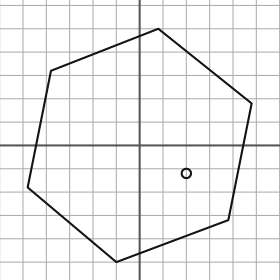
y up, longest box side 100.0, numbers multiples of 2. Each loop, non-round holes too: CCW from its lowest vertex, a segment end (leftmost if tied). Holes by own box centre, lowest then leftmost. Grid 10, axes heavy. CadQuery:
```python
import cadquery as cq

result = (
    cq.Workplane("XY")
    .moveTo(-10.0, -50.0)
    .lineTo(38.0, -32.0)
    .lineTo(48.0, 18.0)
    .lineTo(8.0, 50.0)
    .lineTo(-38.0, 32.0)
    .lineTo(-48.0, -18.0)
    .close()
    .moveTo(20.0, -12.0)
    .circle(2.0)
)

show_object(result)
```